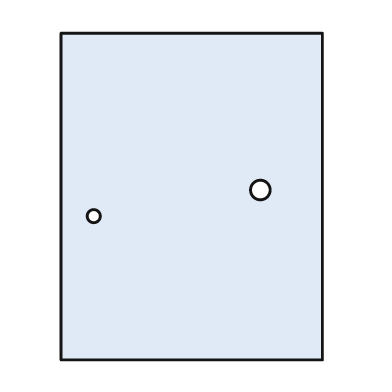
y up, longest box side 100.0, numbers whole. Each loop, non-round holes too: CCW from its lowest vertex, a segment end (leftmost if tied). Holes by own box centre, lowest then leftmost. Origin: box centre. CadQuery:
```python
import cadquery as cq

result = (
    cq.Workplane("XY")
    .moveTo(-40.0, -50.0)
    .lineTo(40.0, -50.0)
    .lineTo(40.0, 50.0)
    .lineTo(-40.0, 50.0)
    .close()
    .moveTo(-30.0, -6.0)
    .circle(2.0)
    .moveTo(21.0, 2.0)
    .circle(3.0)
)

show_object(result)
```